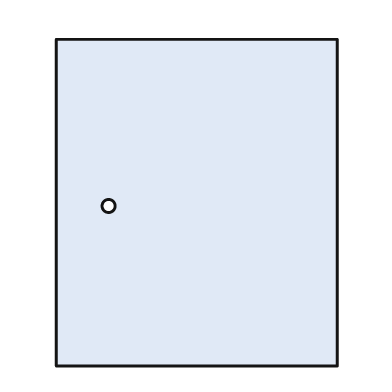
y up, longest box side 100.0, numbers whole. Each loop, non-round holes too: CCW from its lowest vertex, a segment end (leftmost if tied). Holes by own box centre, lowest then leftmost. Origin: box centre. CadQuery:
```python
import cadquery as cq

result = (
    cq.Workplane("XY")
    .moveTo(-43.0, -50.0)
    .lineTo(43.0, -50.0)
    .lineTo(43.0, 50.0)
    .lineTo(-43.0, 50.0)
    .close()
    .moveTo(-27.0, -1.0)
    .circle(2.0)
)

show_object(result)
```